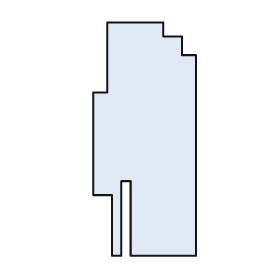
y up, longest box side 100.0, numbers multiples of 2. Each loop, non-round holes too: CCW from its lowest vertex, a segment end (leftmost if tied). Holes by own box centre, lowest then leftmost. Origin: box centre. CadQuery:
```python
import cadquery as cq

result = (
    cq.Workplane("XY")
    .moveTo(-14.0, -50.0)
    .lineTo(-10.0, -50.0)
    .lineTo(-10.0, -18.0)
    .lineTo(-6.0, -18.0)
    .lineTo(-6.0, -50.0)
    .lineTo(22.0, -50.0)
    .lineTo(22.0, 36.0)
    .lineTo(16.0, 36.0)
    .lineTo(16.0, 44.0)
    .lineTo(8.0, 44.0)
    .lineTo(8.0, 50.0)
    .lineTo(-16.0, 50.0)
    .lineTo(-16.0, 20.0)
    .lineTo(-22.0, 20.0)
    .lineTo(-22.0, -24.0)
    .lineTo(-14.0, -24.0)
    .close()
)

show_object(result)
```